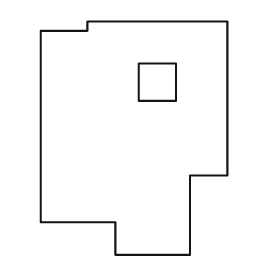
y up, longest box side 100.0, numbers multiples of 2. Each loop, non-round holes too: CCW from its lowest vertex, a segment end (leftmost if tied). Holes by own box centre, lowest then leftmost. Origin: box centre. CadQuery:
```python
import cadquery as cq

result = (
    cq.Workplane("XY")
    .moveTo(-8.0, -50.0)
    .lineTo(24.0, -50.0)
    .lineTo(24.0, -16.0)
    .lineTo(40.0, -16.0)
    .lineTo(40.0, 50.0)
    .lineTo(-20.0, 50.0)
    .lineTo(-20.0, 46.0)
    .lineTo(-40.0, 46.0)
    .lineTo(-40.0, -36.0)
    .lineTo(-8.0, -36.0)
    .close()
    .moveTo(2.0, 16.0)
    .lineTo(18.0, 16.0)
    .lineTo(18.0, 32.0)
    .lineTo(2.0, 32.0)
    .close()
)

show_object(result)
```